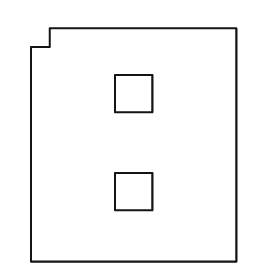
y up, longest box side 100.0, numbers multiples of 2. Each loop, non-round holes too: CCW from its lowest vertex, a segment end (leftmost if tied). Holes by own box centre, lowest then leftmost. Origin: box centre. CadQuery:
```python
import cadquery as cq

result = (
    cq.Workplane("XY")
    .moveTo(-44.0, -50.0)
    .lineTo(44.0, -50.0)
    .lineTo(44.0, 50.0)
    .lineTo(-36.0, 50.0)
    .lineTo(-36.0, 42.0)
    .lineTo(-44.0, 42.0)
    .close()
    .moveTo(-8.0, -28.0)
    .lineTo(8.0, -28.0)
    .lineTo(8.0, -12.0)
    .lineTo(-8.0, -12.0)
    .close()
    .moveTo(-8.0, 14.0)
    .lineTo(8.0, 14.0)
    .lineTo(8.0, 30.0)
    .lineTo(-8.0, 30.0)
    .close()
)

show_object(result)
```